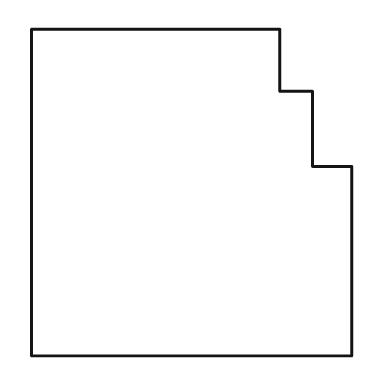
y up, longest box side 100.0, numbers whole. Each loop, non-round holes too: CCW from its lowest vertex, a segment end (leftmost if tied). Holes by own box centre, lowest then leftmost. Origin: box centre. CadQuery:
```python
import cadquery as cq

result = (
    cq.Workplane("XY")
    .moveTo(-49.0, -50.0)
    .lineTo(49.0, -50.0)
    .lineTo(49.0, 8.0)
    .lineTo(37.0, 8.0)
    .lineTo(37.0, 31.0)
    .lineTo(27.0, 31.0)
    .lineTo(27.0, 50.0)
    .lineTo(-49.0, 50.0)
    .close()
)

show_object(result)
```